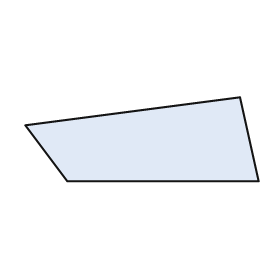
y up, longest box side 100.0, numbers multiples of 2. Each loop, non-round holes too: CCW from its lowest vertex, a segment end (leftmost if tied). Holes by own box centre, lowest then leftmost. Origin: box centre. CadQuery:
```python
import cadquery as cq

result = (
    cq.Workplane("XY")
    .moveTo(-32.0, -18.0)
    .lineTo(50.0, -18.0)
    .lineTo(42.0, 18.0)
    .lineTo(-50.0, 6.0)
    .close()
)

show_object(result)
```